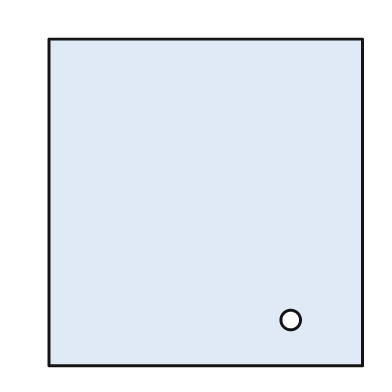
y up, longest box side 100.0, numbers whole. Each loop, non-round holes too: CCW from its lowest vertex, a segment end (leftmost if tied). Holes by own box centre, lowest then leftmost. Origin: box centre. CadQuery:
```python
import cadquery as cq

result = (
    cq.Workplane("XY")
    .moveTo(-48.0, -50.0)
    .lineTo(48.0, -50.0)
    .lineTo(48.0, 50.0)
    .lineTo(-48.0, 50.0)
    .close()
    .moveTo(26.0, -36.0)
    .circle(3.0)
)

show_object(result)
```